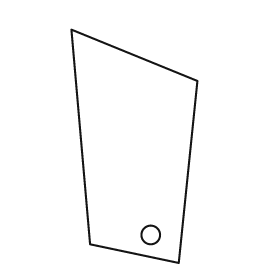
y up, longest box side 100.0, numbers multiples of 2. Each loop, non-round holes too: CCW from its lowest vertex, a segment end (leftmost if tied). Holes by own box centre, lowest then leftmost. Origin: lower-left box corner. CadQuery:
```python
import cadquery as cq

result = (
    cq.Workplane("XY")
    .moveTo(46.0, 0.0)
    .lineTo(54.0, 78.0)
    .lineTo(0.0, 100.0)
    .lineTo(8.0, 8.0)
    .close()
    .moveTo(34.0, 12.0)
    .circle(4.0)
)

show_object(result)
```